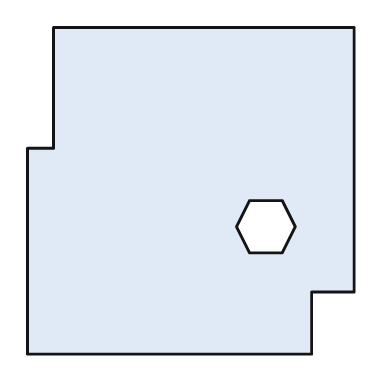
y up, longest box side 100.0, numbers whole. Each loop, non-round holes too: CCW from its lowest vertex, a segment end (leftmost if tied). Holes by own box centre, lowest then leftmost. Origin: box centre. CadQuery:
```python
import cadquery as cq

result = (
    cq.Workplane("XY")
    .moveTo(-50.0, -50.0)
    .lineTo(37.0, -50.0)
    .lineTo(37.0, -31.0)
    .lineTo(50.0, -31.0)
    .lineTo(50.0, 50.0)
    .lineTo(-42.0, 50.0)
    .lineTo(-42.0, 13.0)
    .lineTo(-50.0, 13.0)
    .close()
    .moveTo(18.0, -19.0)
    .lineTo(28.0, -19.0)
    .lineTo(32.0, -11.0)
    .lineTo(28.0, -3.0)
    .lineTo(18.0, -3.0)
    .lineTo(14.0, -11.0)
    .close()
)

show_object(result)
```